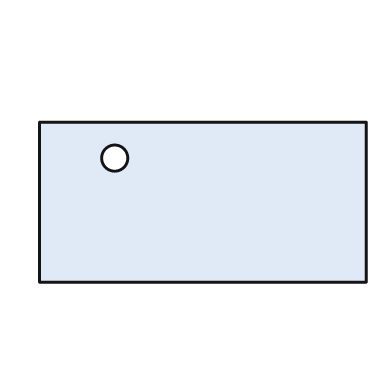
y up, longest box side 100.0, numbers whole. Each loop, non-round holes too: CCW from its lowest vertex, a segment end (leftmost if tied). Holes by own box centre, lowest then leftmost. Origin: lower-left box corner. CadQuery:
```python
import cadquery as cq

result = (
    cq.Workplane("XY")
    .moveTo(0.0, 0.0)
    .lineTo(100.0, 0.0)
    .lineTo(100.0, 49.0)
    .lineTo(0.0, 49.0)
    .close()
    .moveTo(23.0, 38.0)
    .circle(4.0)
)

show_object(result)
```